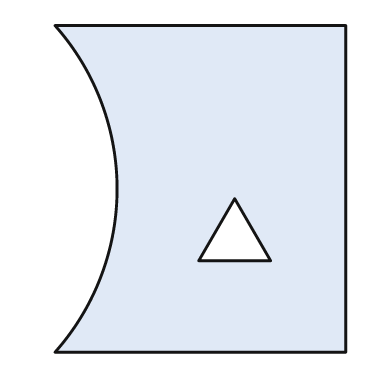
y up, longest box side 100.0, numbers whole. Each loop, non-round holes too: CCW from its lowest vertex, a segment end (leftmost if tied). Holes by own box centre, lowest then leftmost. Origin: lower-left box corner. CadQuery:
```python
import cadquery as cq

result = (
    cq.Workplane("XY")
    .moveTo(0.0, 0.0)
    .lineTo(89.0, 0.0)
    .lineTo(89.0, 100.0)
    .lineTo(0.0, 100.0)
    .threePointArc((19.0, 50.0), (0.0, 0.0))
    .close()
    .moveTo(44.0, 28.0)
    .lineTo(66.0, 28.0)
    .lineTo(55.0, 47.0)
    .close()
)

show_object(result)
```